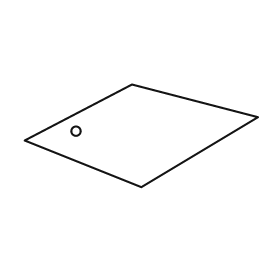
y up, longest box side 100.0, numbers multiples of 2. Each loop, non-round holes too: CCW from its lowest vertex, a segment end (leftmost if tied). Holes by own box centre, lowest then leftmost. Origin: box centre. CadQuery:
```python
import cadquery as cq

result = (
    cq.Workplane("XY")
    .moveTo(0.0, -22.0)
    .lineTo(50.0, 8.0)
    .lineTo(-4.0, 22.0)
    .lineTo(-50.0, -2.0)
    .close()
    .moveTo(-28.0, 2.0)
    .circle(2.0)
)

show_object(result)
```